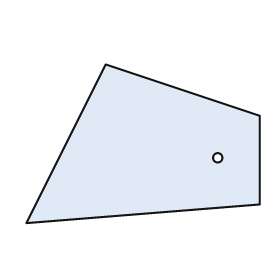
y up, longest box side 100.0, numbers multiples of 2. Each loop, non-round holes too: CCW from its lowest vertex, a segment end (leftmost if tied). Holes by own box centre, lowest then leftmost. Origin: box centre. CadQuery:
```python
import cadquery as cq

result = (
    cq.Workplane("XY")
    .moveTo(-50.0, -34.0)
    .lineTo(50.0, -26.0)
    .lineTo(50.0, 12.0)
    .lineTo(-16.0, 34.0)
    .close()
    .moveTo(32.0, -6.0)
    .circle(2.0)
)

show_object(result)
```